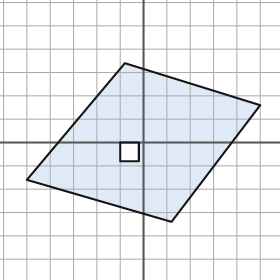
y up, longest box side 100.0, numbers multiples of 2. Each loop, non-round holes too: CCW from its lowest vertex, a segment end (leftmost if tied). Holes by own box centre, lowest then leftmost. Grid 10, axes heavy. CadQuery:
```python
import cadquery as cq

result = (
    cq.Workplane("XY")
    .moveTo(12.0, -34.0)
    .lineTo(50.0, 16.0)
    .lineTo(-8.0, 34.0)
    .lineTo(-50.0, -16.0)
    .close()
    .moveTo(-10.0, -8.0)
    .lineTo(-2.0, -8.0)
    .lineTo(-2.0, 0.0)
    .lineTo(-10.0, 0.0)
    .close()
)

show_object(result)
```